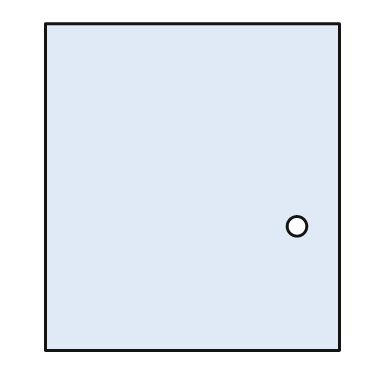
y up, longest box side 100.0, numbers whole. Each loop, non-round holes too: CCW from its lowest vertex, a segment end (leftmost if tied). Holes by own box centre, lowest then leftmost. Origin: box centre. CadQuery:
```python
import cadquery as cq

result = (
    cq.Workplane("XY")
    .moveTo(-45.0, -50.0)
    .lineTo(45.0, -50.0)
    .lineTo(45.0, 50.0)
    .lineTo(-45.0, 50.0)
    .close()
    .moveTo(32.0, -12.0)
    .circle(3.0)
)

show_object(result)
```